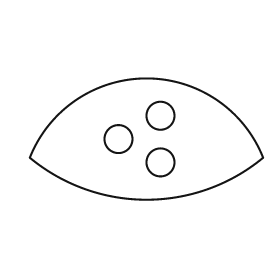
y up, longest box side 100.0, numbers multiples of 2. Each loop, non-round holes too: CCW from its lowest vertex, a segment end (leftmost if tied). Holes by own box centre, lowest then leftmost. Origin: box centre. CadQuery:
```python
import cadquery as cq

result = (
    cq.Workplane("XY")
    .moveTo(-50.0, -8.0)
    .threePointArc((0.0, -26.0), (50.0, -8.0))
    .threePointArc((0.0, 26.0), (-50.0, -8.0))
    .close()
    .moveTo(6.0, -10.0)
    .circle(6.0)
    .moveTo(-12.0, 0.0)
    .circle(6.0)
    .moveTo(6.0, 10.0)
    .circle(6.0)
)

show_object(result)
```